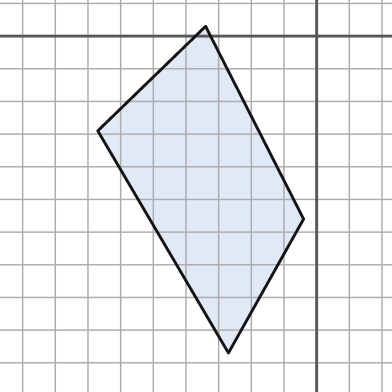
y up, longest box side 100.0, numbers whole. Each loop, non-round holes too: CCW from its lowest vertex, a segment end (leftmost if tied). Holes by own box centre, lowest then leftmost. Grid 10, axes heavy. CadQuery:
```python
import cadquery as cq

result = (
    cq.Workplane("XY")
    .moveTo(-27.0, -97.0)
    .lineTo(-4.0, -56.0)
    .lineTo(-34.0, 3.0)
    .lineTo(-67.0, -29.0)
    .close()
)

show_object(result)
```